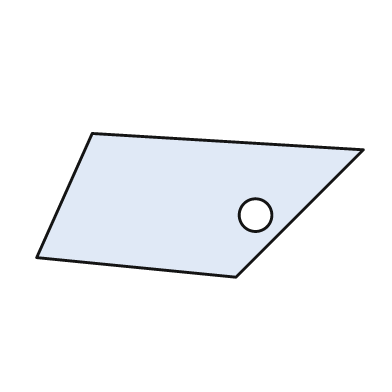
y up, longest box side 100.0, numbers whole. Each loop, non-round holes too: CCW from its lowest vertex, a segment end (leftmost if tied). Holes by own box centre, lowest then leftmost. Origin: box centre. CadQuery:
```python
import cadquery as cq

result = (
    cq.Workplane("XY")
    .moveTo(11.0, -22.0)
    .lineTo(50.0, 17.0)
    .lineTo(-33.0, 22.0)
    .lineTo(-50.0, -16.0)
    .close()
    .moveTo(17.0, -3.0)
    .circle(5.0)
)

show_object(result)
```